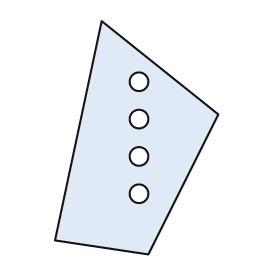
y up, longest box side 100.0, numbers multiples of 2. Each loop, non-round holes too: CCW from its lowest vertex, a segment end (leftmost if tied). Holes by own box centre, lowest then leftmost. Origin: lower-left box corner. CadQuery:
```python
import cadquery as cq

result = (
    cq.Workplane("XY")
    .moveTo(40.0, 0.0)
    .lineTo(70.0, 60.0)
    .lineTo(20.0, 100.0)
    .lineTo(0.0, 6.0)
    .close()
    .moveTo(36.0, 26.0)
    .circle(4.0)
    .moveTo(36.0, 42.0)
    .circle(4.0)
    .moveTo(36.0, 58.0)
    .circle(4.0)
    .moveTo(36.0, 74.0)
    .circle(4.0)
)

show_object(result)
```